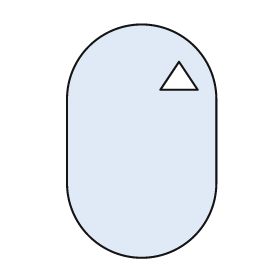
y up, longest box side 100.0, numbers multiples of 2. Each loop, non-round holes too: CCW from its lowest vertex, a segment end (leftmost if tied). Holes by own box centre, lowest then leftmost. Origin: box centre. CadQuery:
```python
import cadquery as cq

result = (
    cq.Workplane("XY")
    .moveTo(-32.0, -18.0)
    .threePointArc((0.0, -50.0), (32.0, -18.0))
    .lineTo(32.0, 18.0)
    .threePointArc((0.0, 50.0), (-32.0, 18.0))
    .close()
    .moveTo(8.0, 22.0)
    .lineTo(24.0, 22.0)
    .lineTo(16.0, 34.0)
    .close()
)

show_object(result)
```